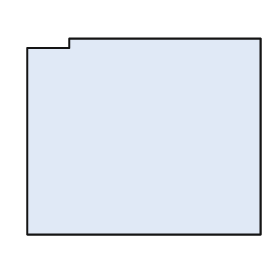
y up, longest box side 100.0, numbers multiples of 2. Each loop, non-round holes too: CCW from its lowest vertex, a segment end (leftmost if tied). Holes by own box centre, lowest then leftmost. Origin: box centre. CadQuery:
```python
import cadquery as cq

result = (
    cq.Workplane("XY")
    .moveTo(-50.0, -42.0)
    .lineTo(50.0, -42.0)
    .lineTo(50.0, 42.0)
    .lineTo(-32.0, 42.0)
    .lineTo(-32.0, 38.0)
    .lineTo(-50.0, 38.0)
    .close()
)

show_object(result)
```